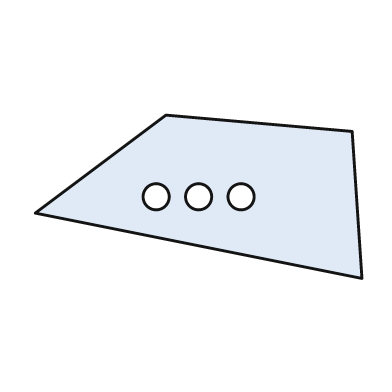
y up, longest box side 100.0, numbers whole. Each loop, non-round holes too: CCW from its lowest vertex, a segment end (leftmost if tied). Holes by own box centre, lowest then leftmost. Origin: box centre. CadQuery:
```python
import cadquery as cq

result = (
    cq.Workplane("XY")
    .moveTo(50.0, -25.0)
    .lineTo(47.0, 20.0)
    .lineTo(-10.0, 25.0)
    .lineTo(-50.0, -5.0)
    .close()
    .moveTo(-13.0, 0.0)
    .circle(4.0)
    .moveTo(0.0, 0.0)
    .circle(4.0)
    .moveTo(13.0, 0.0)
    .circle(4.0)
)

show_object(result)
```